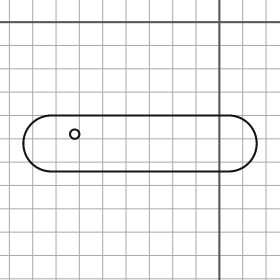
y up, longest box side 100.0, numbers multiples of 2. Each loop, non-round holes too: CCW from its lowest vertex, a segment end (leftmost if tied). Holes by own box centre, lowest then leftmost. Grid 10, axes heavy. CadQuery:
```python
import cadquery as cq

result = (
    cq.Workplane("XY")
    .moveTo(-72.0, -64.0)
    .lineTo(4.0, -64.0)
    .threePointArc((16.0, -52.0), (4.0, -40.0))
    .lineTo(-72.0, -40.0)
    .threePointArc((-84.0, -52.0), (-72.0, -64.0))
    .close()
    .moveTo(-62.0, -48.0)
    .circle(2.0)
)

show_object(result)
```